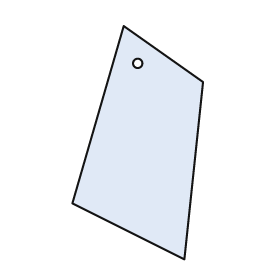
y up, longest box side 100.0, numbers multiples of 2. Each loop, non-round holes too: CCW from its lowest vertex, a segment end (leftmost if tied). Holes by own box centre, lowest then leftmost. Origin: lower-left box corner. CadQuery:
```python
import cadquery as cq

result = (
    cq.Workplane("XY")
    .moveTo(48.0, 0.0)
    .lineTo(56.0, 76.0)
    .lineTo(22.0, 100.0)
    .lineTo(0.0, 24.0)
    .close()
    .moveTo(28.0, 84.0)
    .circle(2.0)
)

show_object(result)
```